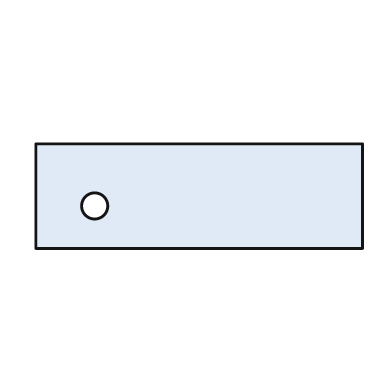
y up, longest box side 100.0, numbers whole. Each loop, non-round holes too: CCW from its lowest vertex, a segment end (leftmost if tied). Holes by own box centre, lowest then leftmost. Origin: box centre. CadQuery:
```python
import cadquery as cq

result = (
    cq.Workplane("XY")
    .moveTo(-50.0, -16.0)
    .lineTo(50.0, -16.0)
    .lineTo(50.0, 16.0)
    .lineTo(-50.0, 16.0)
    .close()
    .moveTo(-32.0, -3.0)
    .circle(4.0)
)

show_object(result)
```